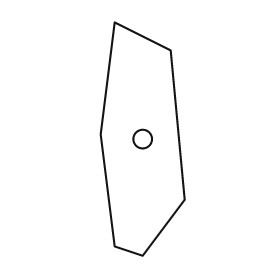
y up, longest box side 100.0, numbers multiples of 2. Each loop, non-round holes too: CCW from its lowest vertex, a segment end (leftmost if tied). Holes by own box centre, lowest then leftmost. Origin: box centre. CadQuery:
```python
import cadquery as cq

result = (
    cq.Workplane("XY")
    .moveTo(0.0, -50.0)
    .lineTo(18.0, -26.0)
    .lineTo(12.0, 38.0)
    .lineTo(-12.0, 50.0)
    .lineTo(-18.0, 2.0)
    .lineTo(-12.0, -46.0)
    .close()
    .moveTo(0.0, 0.0)
    .circle(4.0)
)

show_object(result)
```